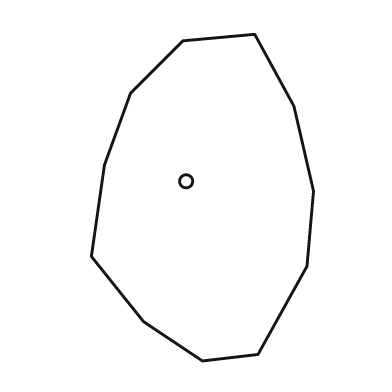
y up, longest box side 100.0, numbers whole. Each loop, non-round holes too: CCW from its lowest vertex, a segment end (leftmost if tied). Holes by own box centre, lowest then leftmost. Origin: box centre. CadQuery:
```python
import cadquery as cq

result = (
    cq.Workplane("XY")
    .moveTo(0.0, -50.0)
    .lineTo(17.0, -48.0)
    .lineTo(32.0, -21.0)
    .lineTo(34.0, 2.0)
    .lineTo(28.0, 28.0)
    .lineTo(16.0, 50.0)
    .lineTo(-6.0, 48.0)
    .lineTo(-22.0, 32.0)
    .lineTo(-30.0, 10.0)
    .lineTo(-34.0, -18.0)
    .lineTo(-18.0, -38.0)
    .close()
    .moveTo(-5.0, 5.0)
    .circle(2.0)
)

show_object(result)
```